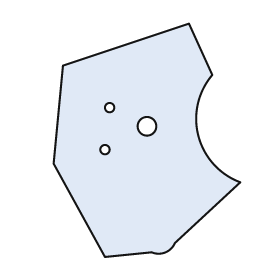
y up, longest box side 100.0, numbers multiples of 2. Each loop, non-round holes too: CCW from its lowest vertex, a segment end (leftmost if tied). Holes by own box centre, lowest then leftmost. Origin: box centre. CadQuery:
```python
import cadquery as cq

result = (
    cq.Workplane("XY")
    .moveTo(-18.0, -50.0)
    .lineTo(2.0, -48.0)
    .threePointArc((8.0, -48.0), (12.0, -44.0))
    .lineTo(40.0, -18.0)
    .threePointArc((22.0, 2.0), (28.0, 28.0))
    .lineTo(18.0, 50.0)
    .lineTo(-36.0, 32.0)
    .lineTo(-40.0, -10.0)
    .close()
    .moveTo(-18.0, -4.0)
    .circle(2.0)
    .moveTo(0.0, 6.0)
    .circle(4.0)
    .moveTo(-16.0, 14.0)
    .circle(2.0)
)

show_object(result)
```